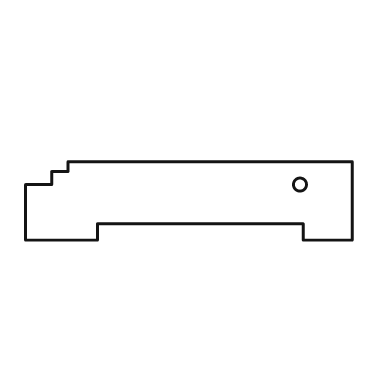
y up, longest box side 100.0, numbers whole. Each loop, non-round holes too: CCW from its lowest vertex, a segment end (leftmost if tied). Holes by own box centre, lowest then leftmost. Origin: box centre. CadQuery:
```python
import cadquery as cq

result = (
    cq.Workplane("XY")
    .moveTo(-50.0, -12.0)
    .lineTo(-28.0, -12.0)
    .lineTo(-28.0, -7.0)
    .lineTo(35.0, -7.0)
    .lineTo(35.0, -12.0)
    .lineTo(50.0, -12.0)
    .lineTo(50.0, 12.0)
    .lineTo(-37.0, 12.0)
    .lineTo(-37.0, 9.0)
    .lineTo(-42.0, 9.0)
    .lineTo(-42.0, 5.0)
    .lineTo(-50.0, 5.0)
    .close()
    .moveTo(34.0, 5.0)
    .circle(2.0)
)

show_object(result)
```